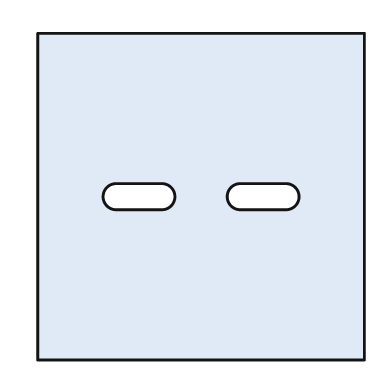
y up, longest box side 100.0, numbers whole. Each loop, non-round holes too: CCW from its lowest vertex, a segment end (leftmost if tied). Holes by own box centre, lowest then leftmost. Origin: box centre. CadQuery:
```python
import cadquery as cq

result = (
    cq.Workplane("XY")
    .moveTo(-50.0, -50.0)
    .lineTo(50.0, -50.0)
    .lineTo(50.0, 50.0)
    .lineTo(-50.0, 50.0)
    .close()
    .moveTo(-26.0, -4.0)
    .lineTo(-12.0, -4.0)
    .threePointArc((-8.0, 0.0), (-12.0, 4.0))
    .lineTo(-26.0, 4.0)
    .threePointArc((-30.0, 0.0), (-26.0, -4.0))
    .close()
    .moveTo(12.0, -4.0)
    .lineTo(26.0, -4.0)
    .threePointArc((30.0, 0.0), (26.0, 4.0))
    .lineTo(12.0, 4.0)
    .threePointArc((8.0, 0.0), (12.0, -4.0))
    .close()
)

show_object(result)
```